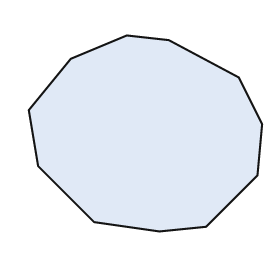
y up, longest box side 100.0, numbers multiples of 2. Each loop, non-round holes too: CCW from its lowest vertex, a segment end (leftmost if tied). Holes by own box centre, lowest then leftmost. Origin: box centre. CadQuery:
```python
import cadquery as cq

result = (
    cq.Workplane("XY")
    .moveTo(6.0, -42.0)
    .lineTo(26.0, -40.0)
    .lineTo(48.0, -18.0)
    .lineTo(50.0, 4.0)
    .lineTo(40.0, 24.0)
    .lineTo(10.0, 40.0)
    .lineTo(-8.0, 42.0)
    .lineTo(-32.0, 32.0)
    .lineTo(-50.0, 10.0)
    .lineTo(-46.0, -14.0)
    .lineTo(-22.0, -38.0)
    .close()
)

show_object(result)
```